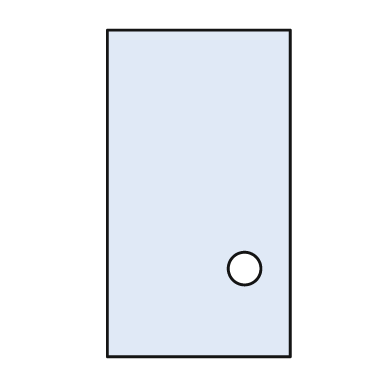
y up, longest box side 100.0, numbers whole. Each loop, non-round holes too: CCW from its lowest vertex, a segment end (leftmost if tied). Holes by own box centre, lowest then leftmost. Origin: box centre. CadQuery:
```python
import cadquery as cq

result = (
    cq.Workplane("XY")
    .moveTo(-28.0, -50.0)
    .lineTo(28.0, -50.0)
    .lineTo(28.0, 50.0)
    .lineTo(-28.0, 50.0)
    .close()
    .moveTo(14.0, -23.0)
    .circle(5.0)
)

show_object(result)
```